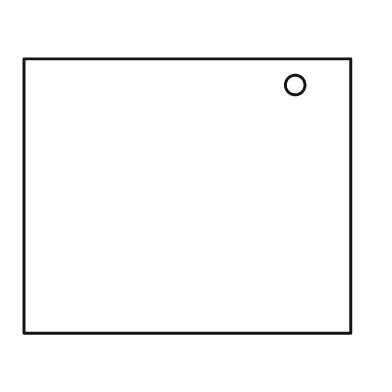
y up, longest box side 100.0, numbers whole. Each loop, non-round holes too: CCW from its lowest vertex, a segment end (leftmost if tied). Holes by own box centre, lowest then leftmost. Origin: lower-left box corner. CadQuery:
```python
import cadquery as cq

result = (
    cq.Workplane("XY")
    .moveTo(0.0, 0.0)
    .lineTo(100.0, 0.0)
    .lineTo(100.0, 84.0)
    .lineTo(0.0, 84.0)
    .close()
    .moveTo(83.0, 76.0)
    .circle(3.0)
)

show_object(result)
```